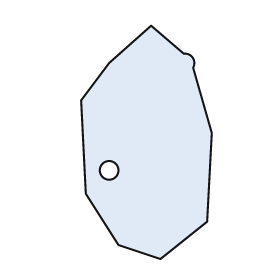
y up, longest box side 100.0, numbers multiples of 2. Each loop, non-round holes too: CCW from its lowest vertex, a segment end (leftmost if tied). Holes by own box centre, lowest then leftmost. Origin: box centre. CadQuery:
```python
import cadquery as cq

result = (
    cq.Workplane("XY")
    .moveTo(6.0, -50.0)
    .lineTo(26.0, -34.0)
    .lineTo(28.0, 4.0)
    .lineTo(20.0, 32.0)
    .threePointArc((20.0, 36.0), (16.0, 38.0))
    .lineTo(2.0, 50.0)
    .lineTo(-16.0, 34.0)
    .lineTo(-28.0, 18.0)
    .lineTo(-26.0, -22.0)
    .lineTo(-12.0, -44.0)
    .close()
    .moveTo(-16.0, -12.0)
    .circle(4.0)
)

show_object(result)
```